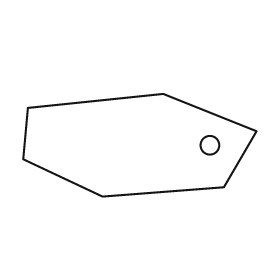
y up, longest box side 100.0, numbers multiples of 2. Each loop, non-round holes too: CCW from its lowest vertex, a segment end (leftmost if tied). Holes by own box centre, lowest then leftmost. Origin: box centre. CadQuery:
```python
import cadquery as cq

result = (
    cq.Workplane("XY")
    .moveTo(-16.0, -22.0)
    .lineTo(36.0, -18.0)
    .lineTo(50.0, 6.0)
    .lineTo(10.0, 22.0)
    .lineTo(-48.0, 16.0)
    .lineTo(-50.0, -6.0)
    .close()
    .moveTo(30.0, 0.0)
    .circle(4.0)
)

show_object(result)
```